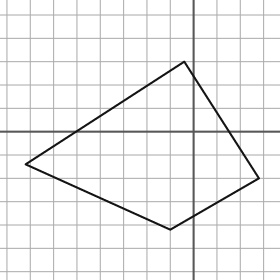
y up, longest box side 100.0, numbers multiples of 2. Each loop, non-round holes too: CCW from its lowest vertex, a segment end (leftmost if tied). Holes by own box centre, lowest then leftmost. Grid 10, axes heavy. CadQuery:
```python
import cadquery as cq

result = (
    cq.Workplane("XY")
    .moveTo(-10.0, -42.0)
    .lineTo(28.0, -20.0)
    .lineTo(-4.0, 30.0)
    .lineTo(-72.0, -14.0)
    .close()
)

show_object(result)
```